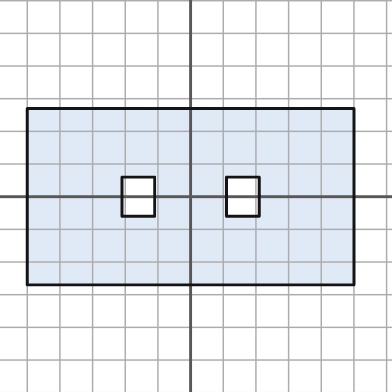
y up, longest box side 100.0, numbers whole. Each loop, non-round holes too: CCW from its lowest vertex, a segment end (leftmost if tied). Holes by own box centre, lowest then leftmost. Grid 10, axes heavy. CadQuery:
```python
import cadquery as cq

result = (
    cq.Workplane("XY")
    .moveTo(-50.0, -27.0)
    .lineTo(50.0, -27.0)
    .lineTo(50.0, 27.0)
    .lineTo(-50.0, 27.0)
    .close()
    .moveTo(-21.0, -6.0)
    .lineTo(-11.0, -6.0)
    .lineTo(-11.0, 6.0)
    .lineTo(-21.0, 6.0)
    .close()
    .moveTo(11.0, -6.0)
    .lineTo(21.0, -6.0)
    .lineTo(21.0, 6.0)
    .lineTo(11.0, 6.0)
    .close()
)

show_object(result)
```